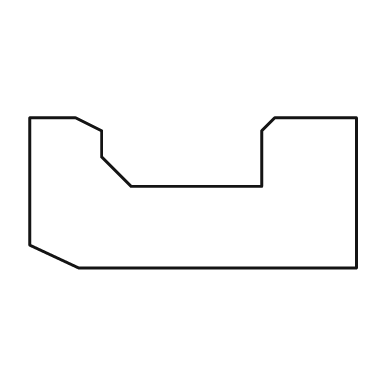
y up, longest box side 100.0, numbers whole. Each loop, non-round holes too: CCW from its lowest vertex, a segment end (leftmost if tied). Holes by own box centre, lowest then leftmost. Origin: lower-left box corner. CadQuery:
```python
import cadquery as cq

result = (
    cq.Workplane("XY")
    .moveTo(15.0, 0.0)
    .lineTo(100.0, 0.0)
    .lineTo(100.0, 46.0)
    .lineTo(75.0, 46.0)
    .lineTo(71.0, 42.0)
    .lineTo(71.0, 25.0)
    .lineTo(31.0, 25.0)
    .lineTo(22.0, 34.0)
    .lineTo(22.0, 42.0)
    .lineTo(14.0, 46.0)
    .lineTo(0.0, 46.0)
    .lineTo(0.0, 7.0)
    .close()
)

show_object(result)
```